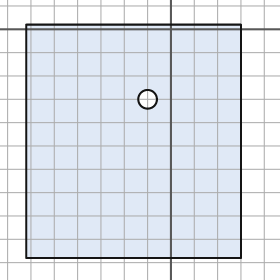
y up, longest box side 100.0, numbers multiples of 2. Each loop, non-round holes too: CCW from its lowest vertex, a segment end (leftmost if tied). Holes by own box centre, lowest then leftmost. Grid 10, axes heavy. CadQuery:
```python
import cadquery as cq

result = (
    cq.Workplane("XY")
    .moveTo(-62.0, -98.0)
    .lineTo(30.0, -98.0)
    .lineTo(30.0, 2.0)
    .lineTo(-62.0, 2.0)
    .close()
    .moveTo(-10.0, -30.0)
    .circle(4.0)
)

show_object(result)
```